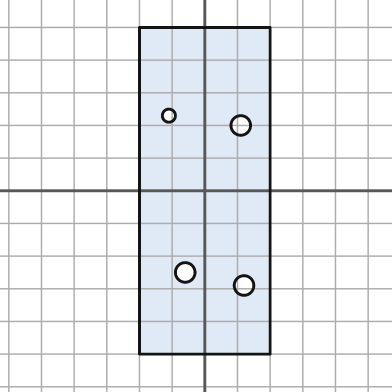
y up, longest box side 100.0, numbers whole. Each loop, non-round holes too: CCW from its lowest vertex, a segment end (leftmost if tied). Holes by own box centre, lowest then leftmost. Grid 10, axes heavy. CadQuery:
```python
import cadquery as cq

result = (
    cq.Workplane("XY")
    .moveTo(-20.0, -50.0)
    .lineTo(20.0, -50.0)
    .lineTo(20.0, 50.0)
    .lineTo(-20.0, 50.0)
    .close()
    .moveTo(12.0, -29.0)
    .circle(3.0)
    .moveTo(-6.0, -25.0)
    .circle(3.0)
    .moveTo(11.0, 20.0)
    .circle(3.0)
    .moveTo(-11.0, 23.0)
    .circle(2.0)
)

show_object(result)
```